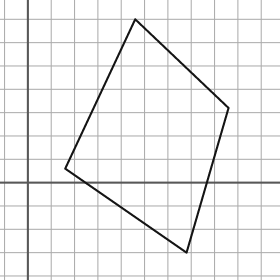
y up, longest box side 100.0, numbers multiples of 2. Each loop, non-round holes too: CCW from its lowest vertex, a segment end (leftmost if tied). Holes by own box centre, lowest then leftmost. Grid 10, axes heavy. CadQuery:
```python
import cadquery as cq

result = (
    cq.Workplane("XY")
    .moveTo(68.0, -30.0)
    .lineTo(86.0, 32.0)
    .lineTo(46.0, 70.0)
    .lineTo(16.0, 6.0)
    .close()
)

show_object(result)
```